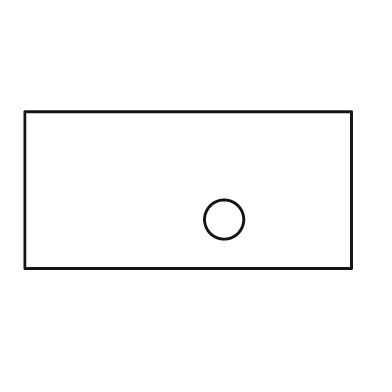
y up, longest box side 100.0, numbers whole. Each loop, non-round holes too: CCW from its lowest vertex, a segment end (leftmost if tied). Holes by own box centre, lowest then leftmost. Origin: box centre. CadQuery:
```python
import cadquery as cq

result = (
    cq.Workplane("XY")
    .moveTo(-50.0, -24.0)
    .lineTo(50.0, -24.0)
    .lineTo(50.0, 24.0)
    .lineTo(-50.0, 24.0)
    .close()
    .moveTo(11.0, -9.0)
    .circle(6.0)
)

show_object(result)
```